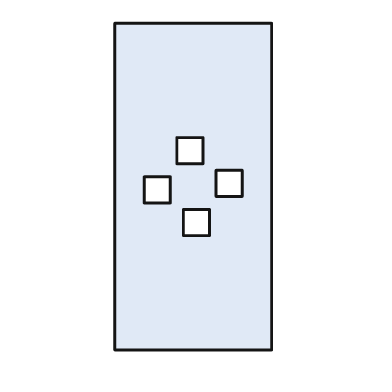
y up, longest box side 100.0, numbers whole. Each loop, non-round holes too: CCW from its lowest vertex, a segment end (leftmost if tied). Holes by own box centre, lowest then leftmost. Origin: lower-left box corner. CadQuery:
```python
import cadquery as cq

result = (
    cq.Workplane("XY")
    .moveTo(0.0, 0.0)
    .lineTo(48.0, 0.0)
    .lineTo(48.0, 100.0)
    .lineTo(0.0, 100.0)
    .close()
    .moveTo(21.0, 35.0)
    .lineTo(29.0, 35.0)
    .lineTo(29.0, 43.0)
    .lineTo(21.0, 43.0)
    .close()
    .moveTo(9.0, 45.0)
    .lineTo(17.0, 45.0)
    .lineTo(17.0, 53.0)
    .lineTo(9.0, 53.0)
    .close()
    .moveTo(31.0, 47.0)
    .lineTo(39.0, 47.0)
    .lineTo(39.0, 55.0)
    .lineTo(31.0, 55.0)
    .close()
    .moveTo(19.0, 57.0)
    .lineTo(27.0, 57.0)
    .lineTo(27.0, 65.0)
    .lineTo(19.0, 65.0)
    .close()
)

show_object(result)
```